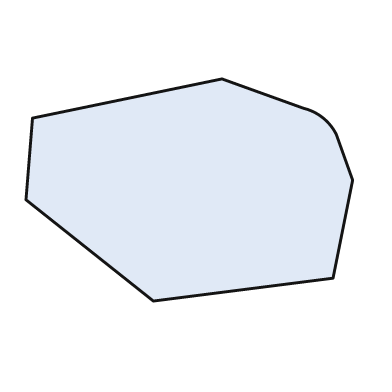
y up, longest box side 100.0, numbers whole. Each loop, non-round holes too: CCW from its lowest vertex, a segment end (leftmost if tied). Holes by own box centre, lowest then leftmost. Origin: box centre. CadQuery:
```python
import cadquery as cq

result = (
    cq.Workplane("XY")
    .moveTo(-11.0, -34.0)
    .lineTo(44.0, -27.0)
    .lineTo(50.0, 3.0)
    .lineTo(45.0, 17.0)
    .threePointArc((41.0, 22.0), (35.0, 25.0))
    .lineTo(10.0, 34.0)
    .lineTo(-48.0, 22.0)
    .lineTo(-50.0, -3.0)
    .close()
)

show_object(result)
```